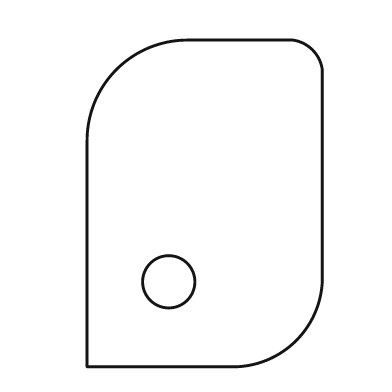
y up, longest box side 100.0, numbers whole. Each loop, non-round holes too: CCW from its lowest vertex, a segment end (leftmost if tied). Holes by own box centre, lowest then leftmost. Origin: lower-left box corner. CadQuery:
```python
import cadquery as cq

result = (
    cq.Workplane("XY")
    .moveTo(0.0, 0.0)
    .lineTo(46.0, 0.0)
    .threePointArc((64.0, 8.0), (72.0, 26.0))
    .lineTo(72.0, 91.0)
    .threePointArc((69.0, 97.0), (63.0, 100.0))
    .lineTo(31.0, 100.0)
    .threePointArc((9.0, 91.0), (0.0, 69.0))
    .close()
    .moveTo(25.0, 26.0)
    .circle(8.0)
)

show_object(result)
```